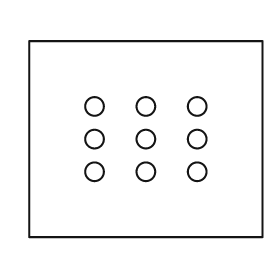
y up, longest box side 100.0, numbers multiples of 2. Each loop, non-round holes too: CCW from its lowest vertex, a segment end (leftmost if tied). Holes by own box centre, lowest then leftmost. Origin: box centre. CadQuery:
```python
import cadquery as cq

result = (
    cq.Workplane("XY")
    .moveTo(-50.0, -42.0)
    .lineTo(50.0, -42.0)
    .lineTo(50.0, 42.0)
    .lineTo(-50.0, 42.0)
    .close()
    .moveTo(-22.0, -14.0)
    .circle(4.0)
    .moveTo(0.0, -14.0)
    .circle(4.0)
    .moveTo(22.0, -14.0)
    .circle(4.0)
    .moveTo(-22.0, 0.0)
    .circle(4.0)
    .moveTo(0.0, 0.0)
    .circle(4.0)
    .moveTo(22.0, 0.0)
    .circle(4.0)
    .moveTo(-22.0, 14.0)
    .circle(4.0)
    .moveTo(0.0, 14.0)
    .circle(4.0)
    .moveTo(22.0, 14.0)
    .circle(4.0)
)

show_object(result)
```